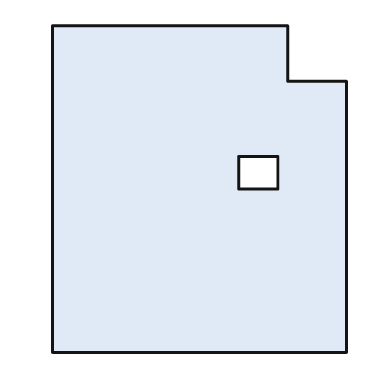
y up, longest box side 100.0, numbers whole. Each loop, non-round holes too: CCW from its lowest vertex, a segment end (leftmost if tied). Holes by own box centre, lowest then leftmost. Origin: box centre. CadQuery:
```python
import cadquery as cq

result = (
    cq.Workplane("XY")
    .moveTo(-45.0, -50.0)
    .lineTo(45.0, -50.0)
    .lineTo(45.0, 33.0)
    .lineTo(27.0, 33.0)
    .lineTo(27.0, 50.0)
    .lineTo(-45.0, 50.0)
    .close()
    .moveTo(12.0, 0.0)
    .lineTo(24.0, 0.0)
    .lineTo(24.0, 10.0)
    .lineTo(12.0, 10.0)
    .close()
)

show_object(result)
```